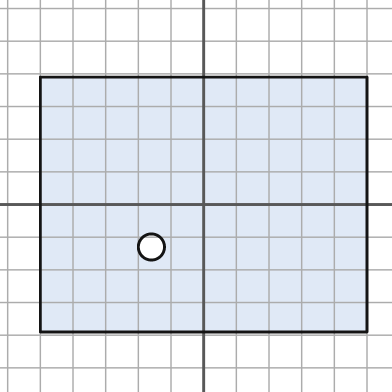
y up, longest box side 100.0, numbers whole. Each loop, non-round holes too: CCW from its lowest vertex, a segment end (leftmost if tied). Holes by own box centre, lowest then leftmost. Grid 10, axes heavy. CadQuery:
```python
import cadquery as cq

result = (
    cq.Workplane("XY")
    .moveTo(-50.0, -39.0)
    .lineTo(50.0, -39.0)
    .lineTo(50.0, 39.0)
    .lineTo(-50.0, 39.0)
    .close()
    .moveTo(-16.0, -13.0)
    .circle(4.0)
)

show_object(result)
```